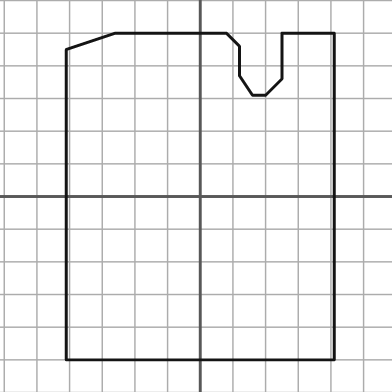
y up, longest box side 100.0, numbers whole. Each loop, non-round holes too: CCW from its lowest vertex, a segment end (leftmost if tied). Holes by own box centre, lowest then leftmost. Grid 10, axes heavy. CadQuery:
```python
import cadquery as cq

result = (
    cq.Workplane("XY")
    .moveTo(-41.0, -50.0)
    .lineTo(41.0, -50.0)
    .lineTo(41.0, 50.0)
    .lineTo(25.0, 50.0)
    .lineTo(25.0, 36.0)
    .lineTo(20.0, 31.0)
    .lineTo(16.0, 31.0)
    .lineTo(12.0, 37.0)
    .lineTo(12.0, 46.0)
    .lineTo(8.0, 50.0)
    .lineTo(-26.0, 50.0)
    .lineTo(-41.0, 45.0)
    .close()
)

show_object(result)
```